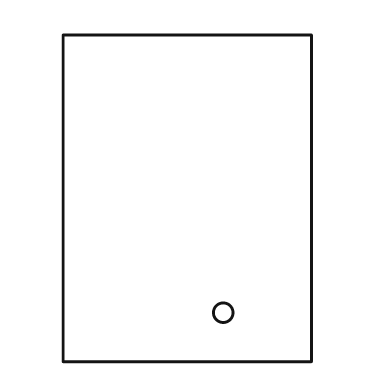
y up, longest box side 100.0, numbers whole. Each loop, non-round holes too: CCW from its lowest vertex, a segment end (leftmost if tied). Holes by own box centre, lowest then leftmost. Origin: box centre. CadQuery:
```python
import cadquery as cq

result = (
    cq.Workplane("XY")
    .moveTo(-38.0, -50.0)
    .lineTo(38.0, -50.0)
    .lineTo(38.0, 50.0)
    .lineTo(-38.0, 50.0)
    .close()
    .moveTo(11.0, -35.0)
    .circle(3.0)
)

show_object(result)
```